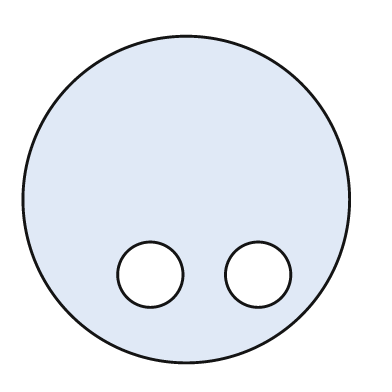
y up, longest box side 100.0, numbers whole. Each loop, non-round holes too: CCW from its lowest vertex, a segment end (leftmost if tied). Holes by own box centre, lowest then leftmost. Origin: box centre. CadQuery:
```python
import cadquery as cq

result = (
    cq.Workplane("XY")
    .moveTo(0.0, 0.0)
    .circle(50.0)
    .moveTo(-11.0, -23.0)
    .circle(10.0)
    .moveTo(22.0, -23.0)
    .circle(10.0)
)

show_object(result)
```